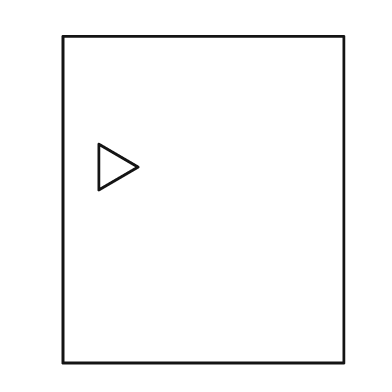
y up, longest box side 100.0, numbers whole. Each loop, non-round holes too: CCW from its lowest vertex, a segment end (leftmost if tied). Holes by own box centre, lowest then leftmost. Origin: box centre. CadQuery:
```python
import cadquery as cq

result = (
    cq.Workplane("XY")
    .moveTo(-43.0, -50.0)
    .lineTo(43.0, -50.0)
    .lineTo(43.0, 50.0)
    .lineTo(-43.0, 50.0)
    .close()
    .moveTo(-32.0, 3.0)
    .lineTo(-20.0, 10.0)
    .lineTo(-32.0, 17.0)
    .close()
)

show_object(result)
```